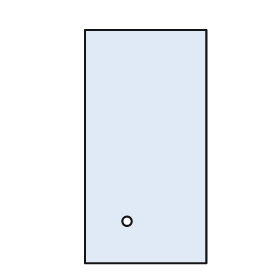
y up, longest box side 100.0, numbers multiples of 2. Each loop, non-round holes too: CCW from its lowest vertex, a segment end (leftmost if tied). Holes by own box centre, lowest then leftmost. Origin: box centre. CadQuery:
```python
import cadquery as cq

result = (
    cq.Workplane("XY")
    .moveTo(-26.0, -50.0)
    .lineTo(26.0, -50.0)
    .lineTo(26.0, 50.0)
    .lineTo(-26.0, 50.0)
    .close()
    .moveTo(-8.0, -32.0)
    .circle(2.0)
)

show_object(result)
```